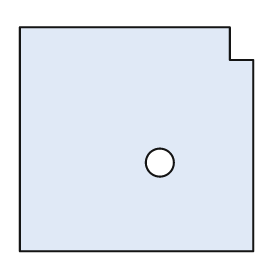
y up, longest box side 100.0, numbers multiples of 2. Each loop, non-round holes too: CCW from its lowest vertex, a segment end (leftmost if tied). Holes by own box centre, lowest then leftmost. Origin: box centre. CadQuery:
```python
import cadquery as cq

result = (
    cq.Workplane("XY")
    .moveTo(-50.0, -48.0)
    .lineTo(50.0, -48.0)
    .lineTo(50.0, 34.0)
    .lineTo(40.0, 34.0)
    .lineTo(40.0, 48.0)
    .lineTo(-50.0, 48.0)
    .close()
    .moveTo(10.0, -10.0)
    .circle(6.0)
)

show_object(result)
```